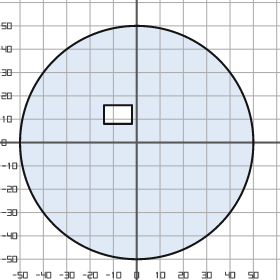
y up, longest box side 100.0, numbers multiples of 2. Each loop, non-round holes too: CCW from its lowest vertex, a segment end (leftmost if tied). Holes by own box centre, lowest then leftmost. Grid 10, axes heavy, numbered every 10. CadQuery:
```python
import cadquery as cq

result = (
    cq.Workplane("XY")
    .moveTo(0.0, 0.0)
    .circle(50.0)
    .moveTo(-14.0, 8.0)
    .lineTo(-2.0, 8.0)
    .lineTo(-2.0, 16.0)
    .lineTo(-14.0, 16.0)
    .close()
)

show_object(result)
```